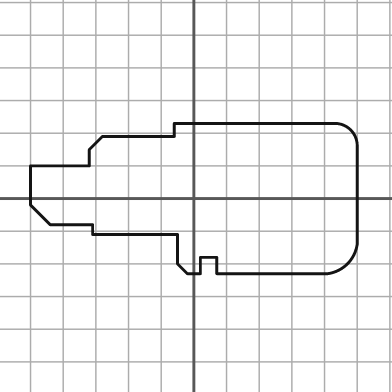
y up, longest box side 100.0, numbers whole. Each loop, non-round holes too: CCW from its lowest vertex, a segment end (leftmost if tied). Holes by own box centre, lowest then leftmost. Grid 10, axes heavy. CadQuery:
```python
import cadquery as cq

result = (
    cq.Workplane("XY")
    .moveTo(-2.0, -23.0)
    .lineTo(2.0, -23.0)
    .lineTo(2.0, -18.0)
    .lineTo(7.0, -18.0)
    .lineTo(7.0, -23.0)
    .lineTo(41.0, -23.0)
    .threePointArc((47.0, -20.0), (50.0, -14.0))
    .lineTo(50.0, 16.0)
    .threePointArc((48.0, 21.0), (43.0, 23.0))
    .lineTo(-6.0, 23.0)
    .lineTo(-6.0, 19.0)
    .lineTo(-28.0, 19.0)
    .lineTo(-32.0, 15.0)
    .lineTo(-32.0, 10.0)
    .lineTo(-50.0, 10.0)
    .lineTo(-50.0, -2.0)
    .lineTo(-44.0, -8.0)
    .lineTo(-31.0, -8.0)
    .lineTo(-31.0, -11.0)
    .lineTo(-5.0, -11.0)
    .lineTo(-5.0, -20.0)
    .close()
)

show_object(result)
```